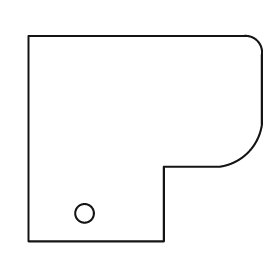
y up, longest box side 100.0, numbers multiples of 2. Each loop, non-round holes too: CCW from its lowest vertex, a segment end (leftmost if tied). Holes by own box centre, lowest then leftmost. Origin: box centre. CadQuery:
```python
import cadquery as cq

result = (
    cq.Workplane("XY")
    .moveTo(-50.0, -44.0)
    .lineTo(8.0, -44.0)
    .lineTo(8.0, -12.0)
    .lineTo(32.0, -12.0)
    .threePointArc((44.0, -6.0), (50.0, 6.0))
    .lineTo(50.0, 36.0)
    .threePointArc((48.0, 42.0), (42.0, 44.0))
    .lineTo(-50.0, 44.0)
    .close()
    .moveTo(-26.0, -32.0)
    .circle(4.0)
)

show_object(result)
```